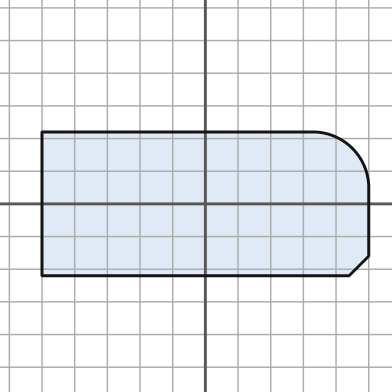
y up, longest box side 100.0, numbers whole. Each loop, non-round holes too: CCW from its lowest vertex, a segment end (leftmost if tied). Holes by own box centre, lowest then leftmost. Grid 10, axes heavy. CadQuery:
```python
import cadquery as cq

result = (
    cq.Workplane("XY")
    .moveTo(-50.0, -22.0)
    .lineTo(44.0, -22.0)
    .lineTo(50.0, -16.0)
    .lineTo(50.0, 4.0)
    .threePointArc((45.0, 17.0), (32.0, 22.0))
    .lineTo(-50.0, 22.0)
    .close()
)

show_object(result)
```